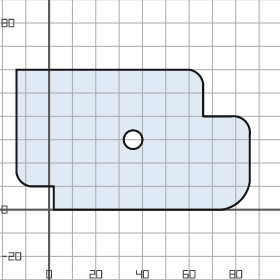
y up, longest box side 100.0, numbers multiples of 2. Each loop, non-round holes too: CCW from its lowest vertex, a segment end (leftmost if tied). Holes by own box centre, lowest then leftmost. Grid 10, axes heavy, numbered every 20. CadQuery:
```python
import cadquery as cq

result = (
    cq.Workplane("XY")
    .moveTo(2.0, 0.0)
    .lineTo(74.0, 0.0)
    .threePointArc((82.0, 4.0), (86.0, 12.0))
    .lineTo(86.0, 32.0)
    .threePointArc((84.0, 38.0), (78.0, 40.0))
    .lineTo(66.0, 40.0)
    .lineTo(66.0, 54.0)
    .threePointArc((64.0, 58.0), (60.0, 60.0))
    .lineTo(-14.0, 60.0)
    .lineTo(-14.0, 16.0)
    .threePointArc((-12.0, 12.0), (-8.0, 10.0))
    .lineTo(2.0, 10.0)
    .close()
    .moveTo(36.0, 30.0)
    .circle(4.0)
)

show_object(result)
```